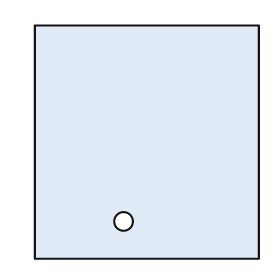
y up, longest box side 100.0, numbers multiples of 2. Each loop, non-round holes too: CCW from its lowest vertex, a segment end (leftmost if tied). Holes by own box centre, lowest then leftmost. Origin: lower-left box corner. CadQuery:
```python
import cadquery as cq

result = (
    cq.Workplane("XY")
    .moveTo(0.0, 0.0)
    .lineTo(96.0, 0.0)
    .lineTo(96.0, 100.0)
    .lineTo(0.0, 100.0)
    .close()
    .moveTo(38.0, 16.0)
    .circle(4.0)
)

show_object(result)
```